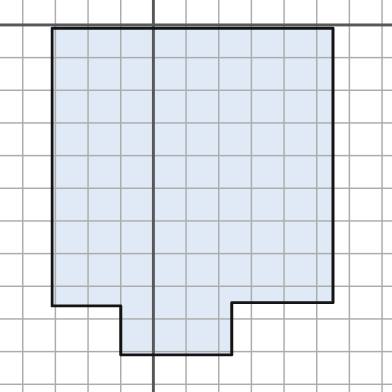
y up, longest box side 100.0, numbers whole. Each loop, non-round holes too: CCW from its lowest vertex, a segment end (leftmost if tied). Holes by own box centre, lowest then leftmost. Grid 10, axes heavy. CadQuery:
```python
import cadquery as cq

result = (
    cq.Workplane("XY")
    .moveTo(-10.0, -101.0)
    .lineTo(24.0, -101.0)
    .lineTo(24.0, -85.0)
    .lineTo(55.0, -85.0)
    .lineTo(55.0, -1.0)
    .lineTo(-31.0, -1.0)
    .lineTo(-31.0, -86.0)
    .lineTo(-10.0, -86.0)
    .close()
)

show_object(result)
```